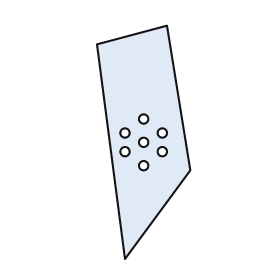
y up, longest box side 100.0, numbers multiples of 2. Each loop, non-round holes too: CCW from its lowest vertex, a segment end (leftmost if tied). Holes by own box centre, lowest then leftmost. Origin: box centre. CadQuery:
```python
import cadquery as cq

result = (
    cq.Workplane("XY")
    .moveTo(-8.0, -50.0)
    .lineTo(20.0, -12.0)
    .lineTo(10.0, 50.0)
    .lineTo(-20.0, 42.0)
    .close()
    .moveTo(0.0, -10.0)
    .circle(2.0)
    .moveTo(-8.0, -4.0)
    .circle(2.0)
    .moveTo(8.0, -4.0)
    .circle(2.0)
    .moveTo(0.0, 0.0)
    .circle(2.0)
    .moveTo(-8.0, 4.0)
    .circle(2.0)
    .moveTo(8.0, 4.0)
    .circle(2.0)
    .moveTo(0.0, 10.0)
    .circle(2.0)
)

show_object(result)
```